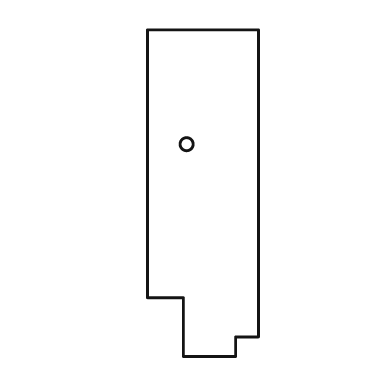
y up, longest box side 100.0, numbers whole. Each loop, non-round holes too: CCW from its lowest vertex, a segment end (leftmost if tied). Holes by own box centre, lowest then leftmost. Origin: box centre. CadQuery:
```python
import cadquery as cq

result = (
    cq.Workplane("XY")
    .moveTo(-6.0, -50.0)
    .lineTo(10.0, -50.0)
    .lineTo(10.0, -44.0)
    .lineTo(17.0, -44.0)
    .lineTo(17.0, 50.0)
    .lineTo(-17.0, 50.0)
    .lineTo(-17.0, -32.0)
    .lineTo(-6.0, -32.0)
    .close()
    .moveTo(-5.0, 15.0)
    .circle(2.0)
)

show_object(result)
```